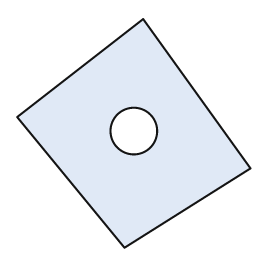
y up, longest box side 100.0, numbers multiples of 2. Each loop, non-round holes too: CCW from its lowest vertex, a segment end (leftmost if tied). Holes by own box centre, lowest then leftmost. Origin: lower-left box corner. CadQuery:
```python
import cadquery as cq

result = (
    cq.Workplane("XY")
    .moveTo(46.0, 0.0)
    .lineTo(100.0, 34.0)
    .lineTo(54.0, 98.0)
    .lineTo(0.0, 56.0)
    .close()
    .moveTo(50.0, 50.0)
    .circle(10.0)
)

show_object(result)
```